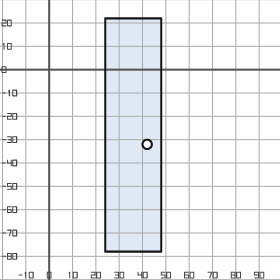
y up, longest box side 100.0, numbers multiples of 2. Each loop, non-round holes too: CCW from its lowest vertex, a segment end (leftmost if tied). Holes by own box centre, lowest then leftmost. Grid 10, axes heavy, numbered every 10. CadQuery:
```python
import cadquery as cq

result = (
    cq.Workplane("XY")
    .moveTo(24.0, -78.0)
    .lineTo(48.0, -78.0)
    .lineTo(48.0, 22.0)
    .lineTo(24.0, 22.0)
    .close()
    .moveTo(42.0, -32.0)
    .circle(2.0)
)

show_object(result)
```